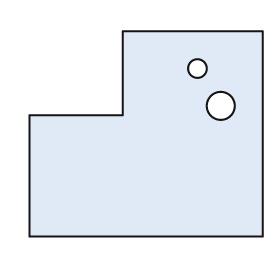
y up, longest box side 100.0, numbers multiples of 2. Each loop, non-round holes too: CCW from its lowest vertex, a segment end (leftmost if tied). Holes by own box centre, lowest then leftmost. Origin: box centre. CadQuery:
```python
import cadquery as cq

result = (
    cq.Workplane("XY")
    .moveTo(-50.0, -44.0)
    .lineTo(50.0, -44.0)
    .lineTo(50.0, 44.0)
    .lineTo(-10.0, 44.0)
    .lineTo(-10.0, 8.0)
    .lineTo(-50.0, 8.0)
    .close()
    .moveTo(32.0, 12.0)
    .circle(6.0)
    .moveTo(22.0, 28.0)
    .circle(4.0)
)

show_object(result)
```